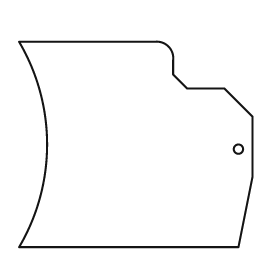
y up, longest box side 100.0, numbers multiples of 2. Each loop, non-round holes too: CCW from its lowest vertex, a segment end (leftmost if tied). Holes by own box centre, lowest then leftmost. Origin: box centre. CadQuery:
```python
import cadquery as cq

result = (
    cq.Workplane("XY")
    .moveTo(-50.0, -44.0)
    .lineTo(44.0, -44.0)
    .lineTo(50.0, -14.0)
    .lineTo(50.0, 12.0)
    .lineTo(38.0, 24.0)
    .lineTo(22.0, 24.0)
    .lineTo(16.0, 30.0)
    .lineTo(16.0, 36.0)
    .threePointArc((14.0, 42.0), (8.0, 44.0))
    .lineTo(-50.0, 44.0)
    .threePointArc((-38.0, 0.0), (-50.0, -44.0))
    .close()
    .moveTo(44.0, -2.0)
    .circle(2.0)
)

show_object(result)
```